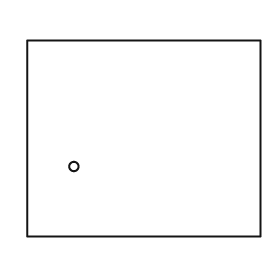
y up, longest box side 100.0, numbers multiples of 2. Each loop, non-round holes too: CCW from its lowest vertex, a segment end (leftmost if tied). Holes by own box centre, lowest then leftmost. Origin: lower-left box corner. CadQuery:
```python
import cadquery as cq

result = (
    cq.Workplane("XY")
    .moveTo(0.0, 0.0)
    .lineTo(100.0, 0.0)
    .lineTo(100.0, 84.0)
    .lineTo(0.0, 84.0)
    .close()
    .moveTo(20.0, 30.0)
    .circle(2.0)
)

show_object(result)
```